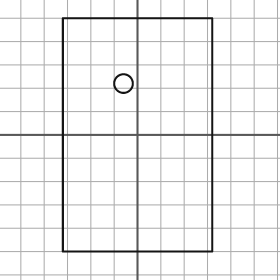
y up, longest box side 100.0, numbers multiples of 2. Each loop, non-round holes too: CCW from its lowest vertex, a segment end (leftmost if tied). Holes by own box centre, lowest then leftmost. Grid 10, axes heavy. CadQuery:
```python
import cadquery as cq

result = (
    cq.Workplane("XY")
    .moveTo(-32.0, -50.0)
    .lineTo(32.0, -50.0)
    .lineTo(32.0, 50.0)
    .lineTo(-32.0, 50.0)
    .close()
    .moveTo(-6.0, 22.0)
    .circle(4.0)
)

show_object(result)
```